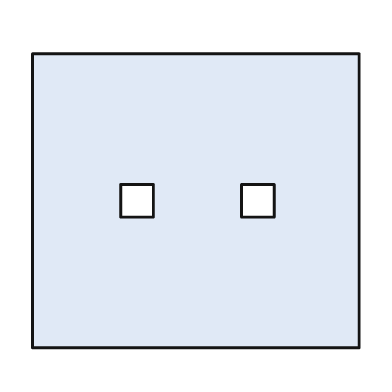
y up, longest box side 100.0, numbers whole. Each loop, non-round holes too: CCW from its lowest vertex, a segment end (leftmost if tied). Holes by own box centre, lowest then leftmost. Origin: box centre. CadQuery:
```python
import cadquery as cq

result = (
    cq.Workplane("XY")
    .moveTo(-50.0, -45.0)
    .lineTo(50.0, -45.0)
    .lineTo(50.0, 45.0)
    .lineTo(-50.0, 45.0)
    .close()
    .moveTo(-23.0, -5.0)
    .lineTo(-13.0, -5.0)
    .lineTo(-13.0, 5.0)
    .lineTo(-23.0, 5.0)
    .close()
    .moveTo(14.0, -5.0)
    .lineTo(24.0, -5.0)
    .lineTo(24.0, 5.0)
    .lineTo(14.0, 5.0)
    .close()
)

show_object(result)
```